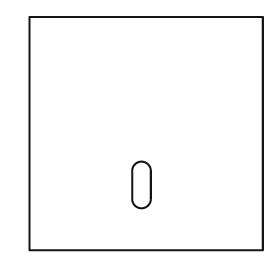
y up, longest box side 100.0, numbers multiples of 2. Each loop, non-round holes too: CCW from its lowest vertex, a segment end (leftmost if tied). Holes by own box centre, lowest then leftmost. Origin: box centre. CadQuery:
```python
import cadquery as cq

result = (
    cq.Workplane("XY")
    .moveTo(-50.0, -50.0)
    .lineTo(50.0, -50.0)
    .lineTo(50.0, 50.0)
    .lineTo(-50.0, 50.0)
    .close()
    .moveTo(-6.0, -28.0)
    .threePointArc((-2.0, -32.0), (2.0, -28.0))
    .lineTo(2.0, -16.0)
    .threePointArc((-2.0, -12.0), (-6.0, -16.0))
    .close()
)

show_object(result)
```